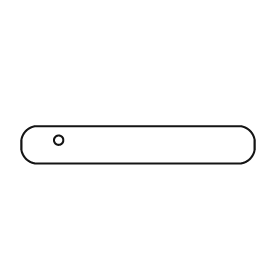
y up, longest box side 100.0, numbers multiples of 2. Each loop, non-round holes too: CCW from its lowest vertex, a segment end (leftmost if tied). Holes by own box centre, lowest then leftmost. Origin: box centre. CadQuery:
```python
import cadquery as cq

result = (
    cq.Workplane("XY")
    .moveTo(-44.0, -8.0)
    .lineTo(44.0, -8.0)
    .threePointArc((48.0, -6.0), (50.0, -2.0))
    .lineTo(50.0, 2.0)
    .threePointArc((48.0, 6.0), (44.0, 8.0))
    .lineTo(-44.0, 8.0)
    .threePointArc((-48.0, 6.0), (-50.0, 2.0))
    .lineTo(-50.0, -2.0)
    .threePointArc((-48.0, -6.0), (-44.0, -8.0))
    .close()
    .moveTo(-34.0, 2.0)
    .circle(2.0)
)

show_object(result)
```